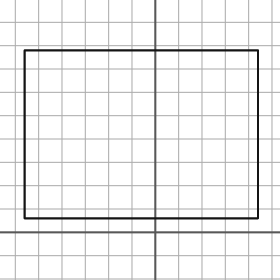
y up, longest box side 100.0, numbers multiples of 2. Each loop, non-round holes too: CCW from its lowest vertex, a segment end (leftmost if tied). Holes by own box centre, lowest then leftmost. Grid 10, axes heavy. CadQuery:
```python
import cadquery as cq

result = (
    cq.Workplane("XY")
    .moveTo(-56.0, 6.0)
    .lineTo(44.0, 6.0)
    .lineTo(44.0, 78.0)
    .lineTo(-56.0, 78.0)
    .close()
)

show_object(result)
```